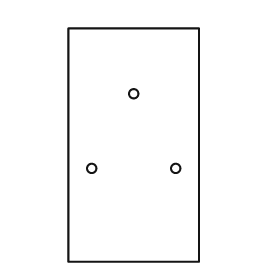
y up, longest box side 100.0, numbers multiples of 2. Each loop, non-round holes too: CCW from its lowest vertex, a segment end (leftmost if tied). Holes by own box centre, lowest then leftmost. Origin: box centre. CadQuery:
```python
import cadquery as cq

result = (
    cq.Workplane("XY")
    .moveTo(-28.0, -50.0)
    .lineTo(28.0, -50.0)
    .lineTo(28.0, 50.0)
    .lineTo(-28.0, 50.0)
    .close()
    .moveTo(-18.0, -10.0)
    .circle(2.0)
    .moveTo(18.0, -10.0)
    .circle(2.0)
    .moveTo(0.0, 22.0)
    .circle(2.0)
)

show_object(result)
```